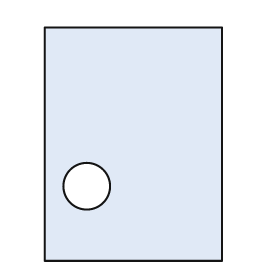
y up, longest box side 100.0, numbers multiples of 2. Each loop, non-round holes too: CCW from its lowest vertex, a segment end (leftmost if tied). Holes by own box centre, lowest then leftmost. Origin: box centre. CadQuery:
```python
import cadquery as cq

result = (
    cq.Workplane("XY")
    .moveTo(-38.0, -50.0)
    .lineTo(38.0, -50.0)
    .lineTo(38.0, 50.0)
    .lineTo(-38.0, 50.0)
    .close()
    .moveTo(-20.0, -18.0)
    .circle(10.0)
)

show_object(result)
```